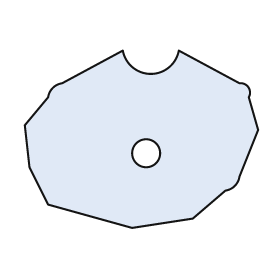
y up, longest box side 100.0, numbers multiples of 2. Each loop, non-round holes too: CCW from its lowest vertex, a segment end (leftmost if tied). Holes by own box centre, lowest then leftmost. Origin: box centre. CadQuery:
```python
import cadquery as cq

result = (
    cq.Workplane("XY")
    .moveTo(-4.0, -38.0)
    .lineTo(22.0, -34.0)
    .lineTo(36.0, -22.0)
    .threePointArc((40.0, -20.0), (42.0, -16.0))
    .lineTo(50.0, 4.0)
    .lineTo(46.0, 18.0)
    .threePointArc((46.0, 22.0), (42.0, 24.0))
    .lineTo(16.0, 38.0)
    .threePointArc((4.0, 28.0), (-8.0, 38.0))
    .lineTo(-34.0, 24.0)
    .threePointArc((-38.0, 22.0), (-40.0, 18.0))
    .lineTo(-50.0, 6.0)
    .lineTo(-48.0, -12.0)
    .lineTo(-40.0, -28.0)
    .close()
    .moveTo(2.0, -6.0)
    .circle(6.0)
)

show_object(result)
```